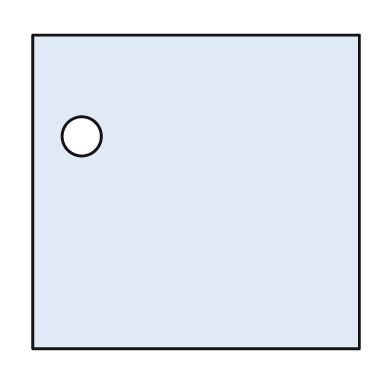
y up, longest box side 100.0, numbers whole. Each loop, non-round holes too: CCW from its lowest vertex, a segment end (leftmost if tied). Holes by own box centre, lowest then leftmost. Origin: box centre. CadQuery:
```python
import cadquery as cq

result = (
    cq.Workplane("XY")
    .moveTo(-50.0, -48.0)
    .lineTo(50.0, -48.0)
    .lineTo(50.0, 48.0)
    .lineTo(-50.0, 48.0)
    .close()
    .moveTo(-35.0, 17.0)
    .circle(6.0)
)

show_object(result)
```